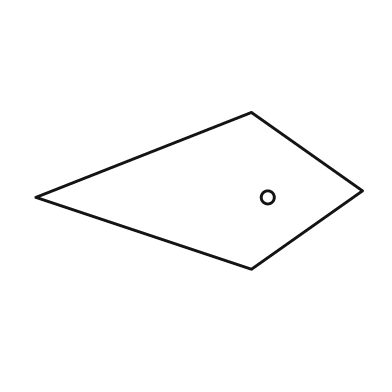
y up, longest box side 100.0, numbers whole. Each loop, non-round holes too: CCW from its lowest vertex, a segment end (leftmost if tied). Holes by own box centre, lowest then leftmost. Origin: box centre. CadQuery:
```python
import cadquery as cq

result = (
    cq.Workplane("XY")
    .moveTo(16.0, -24.0)
    .lineTo(50.0, 0.0)
    .lineTo(16.0, 24.0)
    .lineTo(-50.0, -2.0)
    .close()
    .moveTo(21.0, -2.0)
    .circle(2.0)
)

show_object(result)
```